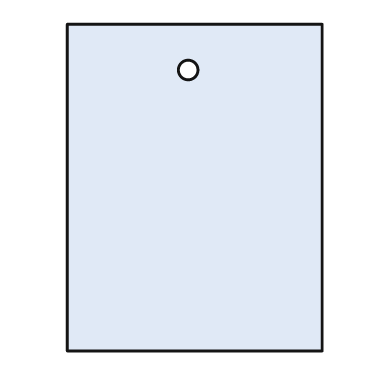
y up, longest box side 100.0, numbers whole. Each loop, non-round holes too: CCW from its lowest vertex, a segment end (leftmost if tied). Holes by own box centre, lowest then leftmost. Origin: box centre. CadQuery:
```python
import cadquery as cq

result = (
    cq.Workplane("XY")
    .moveTo(-39.0, -50.0)
    .lineTo(39.0, -50.0)
    .lineTo(39.0, 50.0)
    .lineTo(-39.0, 50.0)
    .close()
    .moveTo(-2.0, 36.0)
    .circle(3.0)
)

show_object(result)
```